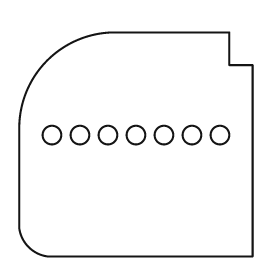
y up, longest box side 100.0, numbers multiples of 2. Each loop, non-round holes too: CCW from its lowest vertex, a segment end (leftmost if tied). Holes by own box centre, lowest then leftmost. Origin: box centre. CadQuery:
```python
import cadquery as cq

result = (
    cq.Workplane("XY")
    .moveTo(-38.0, -48.0)
    .lineTo(50.0, -48.0)
    .lineTo(50.0, 34.0)
    .lineTo(40.0, 34.0)
    .lineTo(40.0, 48.0)
    .lineTo(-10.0, 48.0)
    .threePointArc((-38.0, 36.0), (-50.0, 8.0))
    .lineTo(-50.0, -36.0)
    .threePointArc((-46.0, -44.0), (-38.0, -48.0))
    .close()
    .moveTo(-36.0, 4.0)
    .circle(4.0)
    .moveTo(-24.0, 4.0)
    .circle(4.0)
    .moveTo(-12.0, 4.0)
    .circle(4.0)
    .moveTo(0.0, 4.0)
    .circle(4.0)
    .moveTo(12.0, 4.0)
    .circle(4.0)
    .moveTo(24.0, 4.0)
    .circle(4.0)
    .moveTo(36.0, 4.0)
    .circle(4.0)
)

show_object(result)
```